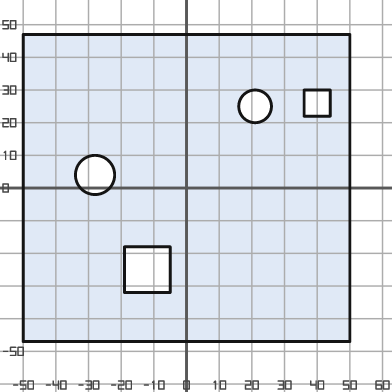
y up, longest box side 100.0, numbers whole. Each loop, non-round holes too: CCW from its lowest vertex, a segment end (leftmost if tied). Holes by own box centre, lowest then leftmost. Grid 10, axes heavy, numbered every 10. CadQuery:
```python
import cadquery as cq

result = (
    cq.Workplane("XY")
    .moveTo(-50.0, -47.0)
    .lineTo(50.0, -47.0)
    .lineTo(50.0, 47.0)
    .lineTo(-50.0, 47.0)
    .close()
    .moveTo(-19.0, -32.0)
    .lineTo(-5.0, -32.0)
    .lineTo(-5.0, -18.0)
    .lineTo(-19.0, -18.0)
    .close()
    .moveTo(-28.0, 4.0)
    .circle(6.0)
    .moveTo(21.0, 25.0)
    .circle(5.0)
    .moveTo(36.0, 22.0)
    .lineTo(44.0, 22.0)
    .lineTo(44.0, 30.0)
    .lineTo(36.0, 30.0)
    .close()
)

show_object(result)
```